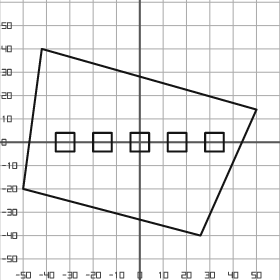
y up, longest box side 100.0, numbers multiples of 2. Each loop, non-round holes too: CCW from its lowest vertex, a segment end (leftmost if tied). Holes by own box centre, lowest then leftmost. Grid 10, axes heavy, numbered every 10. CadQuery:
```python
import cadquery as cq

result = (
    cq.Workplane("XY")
    .moveTo(26.0, -40.0)
    .lineTo(50.0, 14.0)
    .lineTo(-42.0, 40.0)
    .lineTo(-50.0, -20.0)
    .close()
    .moveTo(-36.0, -4.0)
    .lineTo(-28.0, -4.0)
    .lineTo(-28.0, 4.0)
    .lineTo(-36.0, 4.0)
    .close()
    .moveTo(-20.0, -4.0)
    .lineTo(-12.0, -4.0)
    .lineTo(-12.0, 4.0)
    .lineTo(-20.0, 4.0)
    .close()
    .moveTo(-4.0, -4.0)
    .lineTo(4.0, -4.0)
    .lineTo(4.0, 4.0)
    .lineTo(-4.0, 4.0)
    .close()
    .moveTo(12.0, -4.0)
    .lineTo(20.0, -4.0)
    .lineTo(20.0, 4.0)
    .lineTo(12.0, 4.0)
    .close()
    .moveTo(28.0, -4.0)
    .lineTo(36.0, -4.0)
    .lineTo(36.0, 4.0)
    .lineTo(28.0, 4.0)
    .close()
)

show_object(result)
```